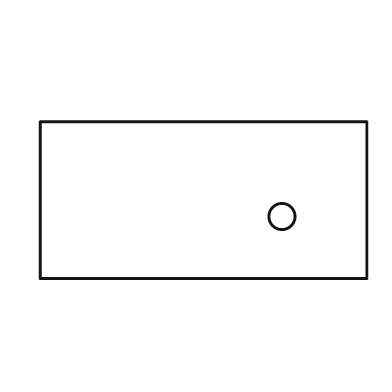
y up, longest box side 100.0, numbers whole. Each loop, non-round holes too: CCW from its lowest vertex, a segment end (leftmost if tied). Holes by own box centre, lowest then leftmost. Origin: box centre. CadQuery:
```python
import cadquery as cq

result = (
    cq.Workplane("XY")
    .moveTo(-50.0, -24.0)
    .lineTo(50.0, -24.0)
    .lineTo(50.0, 24.0)
    .lineTo(-50.0, 24.0)
    .close()
    .moveTo(24.0, -5.0)
    .circle(4.0)
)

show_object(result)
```